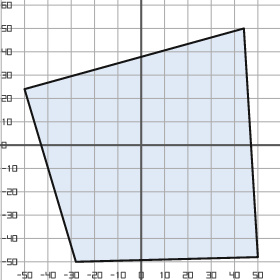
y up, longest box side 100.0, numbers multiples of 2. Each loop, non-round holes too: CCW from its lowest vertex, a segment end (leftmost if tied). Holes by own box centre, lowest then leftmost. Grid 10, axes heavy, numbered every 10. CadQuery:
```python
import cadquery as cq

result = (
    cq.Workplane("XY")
    .moveTo(-28.0, -50.0)
    .lineTo(50.0, -48.0)
    .lineTo(44.0, 50.0)
    .lineTo(-50.0, 24.0)
    .close()
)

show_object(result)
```